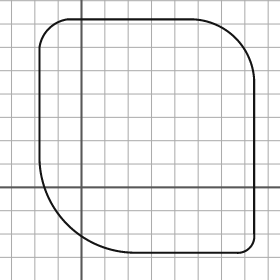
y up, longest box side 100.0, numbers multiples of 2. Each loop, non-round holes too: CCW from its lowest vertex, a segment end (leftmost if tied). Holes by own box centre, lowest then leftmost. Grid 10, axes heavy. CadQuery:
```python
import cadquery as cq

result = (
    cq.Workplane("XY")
    .moveTo(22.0, -28.0)
    .lineTo(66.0, -28.0)
    .threePointArc((72.0, -26.0), (74.0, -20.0))
    .lineTo(74.0, 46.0)
    .threePointArc((66.0, 64.0), (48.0, 72.0))
    .lineTo(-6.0, 72.0)
    .threePointArc((-14.0, 68.0), (-18.0, 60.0))
    .lineTo(-18.0, 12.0)
    .threePointArc((-6.0, -16.0), (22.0, -28.0))
    .close()
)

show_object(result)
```